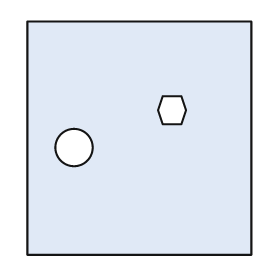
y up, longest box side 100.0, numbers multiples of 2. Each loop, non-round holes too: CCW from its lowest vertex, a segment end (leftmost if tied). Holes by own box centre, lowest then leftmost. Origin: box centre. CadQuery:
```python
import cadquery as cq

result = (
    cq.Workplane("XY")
    .moveTo(-48.0, -50.0)
    .lineTo(48.0, -50.0)
    .lineTo(48.0, 50.0)
    .lineTo(-48.0, 50.0)
    .close()
    .moveTo(-28.0, -4.0)
    .circle(8.0)
    .moveTo(10.0, 6.0)
    .lineTo(18.0, 6.0)
    .lineTo(20.0, 12.0)
    .lineTo(18.0, 18.0)
    .lineTo(10.0, 18.0)
    .lineTo(8.0, 12.0)
    .close()
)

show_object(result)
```